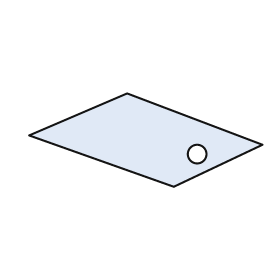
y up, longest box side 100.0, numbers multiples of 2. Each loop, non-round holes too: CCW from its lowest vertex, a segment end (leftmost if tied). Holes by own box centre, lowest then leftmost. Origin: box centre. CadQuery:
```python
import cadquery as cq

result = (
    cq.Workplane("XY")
    .moveTo(12.0, -20.0)
    .lineTo(50.0, -2.0)
    .lineTo(-8.0, 20.0)
    .lineTo(-50.0, 2.0)
    .close()
    .moveTo(22.0, -6.0)
    .circle(4.0)
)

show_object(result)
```